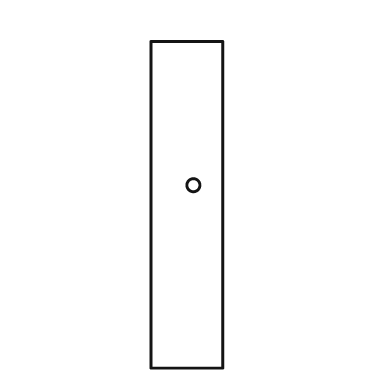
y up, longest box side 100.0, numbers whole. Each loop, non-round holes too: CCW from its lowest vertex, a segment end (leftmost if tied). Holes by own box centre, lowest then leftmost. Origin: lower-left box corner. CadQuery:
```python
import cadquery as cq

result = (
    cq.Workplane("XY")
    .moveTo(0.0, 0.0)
    .lineTo(22.0, 0.0)
    .lineTo(22.0, 100.0)
    .lineTo(0.0, 100.0)
    .close()
    .moveTo(13.0, 56.0)
    .circle(2.0)
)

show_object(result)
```